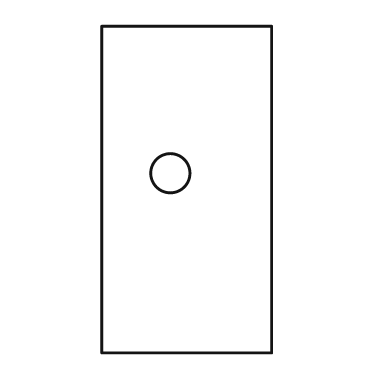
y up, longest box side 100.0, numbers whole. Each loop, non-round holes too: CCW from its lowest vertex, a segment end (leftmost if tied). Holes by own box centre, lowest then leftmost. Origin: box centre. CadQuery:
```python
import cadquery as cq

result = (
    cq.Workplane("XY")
    .moveTo(-26.0, -50.0)
    .lineTo(26.0, -50.0)
    .lineTo(26.0, 50.0)
    .lineTo(-26.0, 50.0)
    .close()
    .moveTo(-5.0, 5.0)
    .circle(6.0)
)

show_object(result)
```